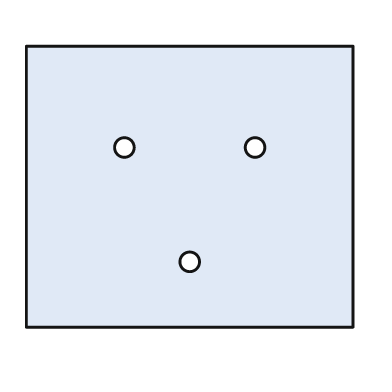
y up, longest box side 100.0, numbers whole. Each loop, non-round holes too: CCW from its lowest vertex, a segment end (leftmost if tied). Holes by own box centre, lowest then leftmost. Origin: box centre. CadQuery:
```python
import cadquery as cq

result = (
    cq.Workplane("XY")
    .moveTo(-50.0, -43.0)
    .lineTo(50.0, -43.0)
    .lineTo(50.0, 43.0)
    .lineTo(-50.0, 43.0)
    .close()
    .moveTo(0.0, -23.0)
    .circle(3.0)
    .moveTo(-20.0, 12.0)
    .circle(3.0)
    .moveTo(20.0, 12.0)
    .circle(3.0)
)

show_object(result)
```